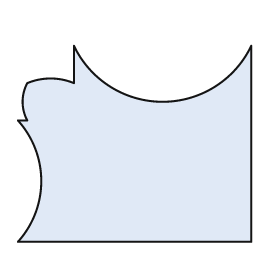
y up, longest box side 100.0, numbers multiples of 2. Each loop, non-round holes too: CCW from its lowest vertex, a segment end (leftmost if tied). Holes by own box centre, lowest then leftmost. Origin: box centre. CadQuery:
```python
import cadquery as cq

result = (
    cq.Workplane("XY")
    .moveTo(-50.0, -42.0)
    .lineTo(50.0, -42.0)
    .lineTo(50.0, 42.0)
    .threePointArc((12.0, 18.0), (-26.0, 42.0))
    .lineTo(-26.0, 26.0)
    .threePointArc((-36.0, 28.0), (-46.0, 26.0))
    .threePointArc((-48.0, 18.0), (-46.0, 10.0))
    .lineTo(-50.0, 10.0)
    .threePointArc((-40.0, -16.0), (-50.0, -42.0))
    .close()
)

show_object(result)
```